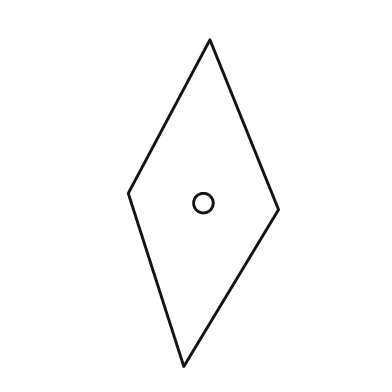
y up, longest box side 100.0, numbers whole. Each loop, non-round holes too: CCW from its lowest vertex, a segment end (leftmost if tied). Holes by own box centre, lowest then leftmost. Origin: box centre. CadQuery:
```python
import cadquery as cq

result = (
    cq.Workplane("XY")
    .moveTo(-6.0, -50.0)
    .lineTo(23.0, -2.0)
    .lineTo(2.0, 50.0)
    .lineTo(-23.0, 3.0)
    .close()
    .moveTo(0.0, 0.0)
    .circle(3.0)
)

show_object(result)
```